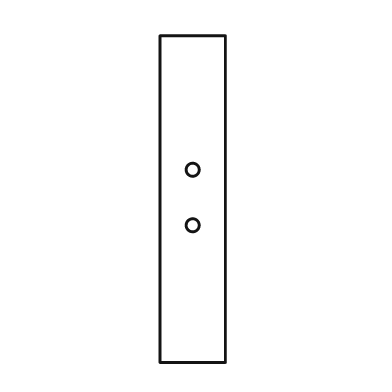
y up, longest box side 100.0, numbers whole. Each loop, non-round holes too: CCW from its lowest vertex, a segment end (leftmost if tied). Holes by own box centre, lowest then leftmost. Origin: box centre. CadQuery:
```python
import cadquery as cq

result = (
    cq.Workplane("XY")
    .moveTo(-10.0, -50.0)
    .lineTo(10.0, -50.0)
    .lineTo(10.0, 50.0)
    .lineTo(-10.0, 50.0)
    .close()
    .moveTo(0.0, -8.0)
    .circle(2.0)
    .moveTo(0.0, 9.0)
    .circle(2.0)
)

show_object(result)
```